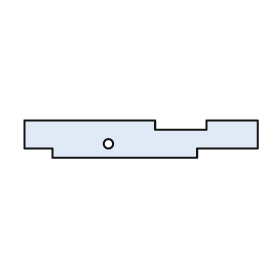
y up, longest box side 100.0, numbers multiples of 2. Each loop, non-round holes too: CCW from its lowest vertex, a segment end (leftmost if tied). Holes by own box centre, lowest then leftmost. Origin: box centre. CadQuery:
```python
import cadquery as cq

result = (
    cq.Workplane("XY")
    .moveTo(-38.0, -8.0)
    .lineTo(24.0, -8.0)
    .lineTo(24.0, -4.0)
    .lineTo(50.0, -4.0)
    .lineTo(50.0, 8.0)
    .lineTo(28.0, 8.0)
    .lineTo(28.0, 4.0)
    .lineTo(6.0, 4.0)
    .lineTo(6.0, 8.0)
    .lineTo(-50.0, 8.0)
    .lineTo(-50.0, -4.0)
    .lineTo(-38.0, -4.0)
    .close()
    .moveTo(-14.0, -2.0)
    .circle(2.0)
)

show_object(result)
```